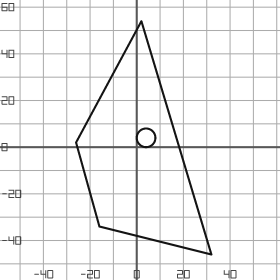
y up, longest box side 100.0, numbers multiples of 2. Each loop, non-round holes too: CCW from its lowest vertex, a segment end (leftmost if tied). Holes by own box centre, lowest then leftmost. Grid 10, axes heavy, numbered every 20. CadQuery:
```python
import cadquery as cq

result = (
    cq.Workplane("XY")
    .moveTo(32.0, -46.0)
    .lineTo(2.0, 54.0)
    .lineTo(-26.0, 2.0)
    .lineTo(-16.0, -34.0)
    .close()
    .moveTo(4.0, 4.0)
    .circle(4.0)
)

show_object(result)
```